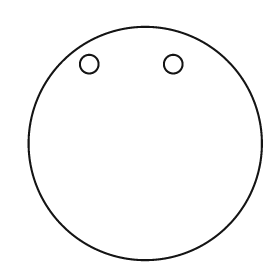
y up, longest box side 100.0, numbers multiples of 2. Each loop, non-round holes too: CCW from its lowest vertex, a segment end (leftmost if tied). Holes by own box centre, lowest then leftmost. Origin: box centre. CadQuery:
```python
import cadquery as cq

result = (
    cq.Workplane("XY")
    .moveTo(0.0, 0.0)
    .circle(50.0)
    .moveTo(-24.0, 34.0)
    .circle(4.0)
    .moveTo(12.0, 34.0)
    .circle(4.0)
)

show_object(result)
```